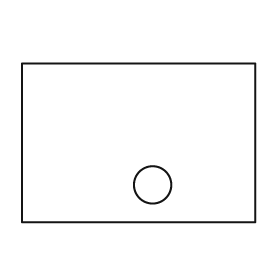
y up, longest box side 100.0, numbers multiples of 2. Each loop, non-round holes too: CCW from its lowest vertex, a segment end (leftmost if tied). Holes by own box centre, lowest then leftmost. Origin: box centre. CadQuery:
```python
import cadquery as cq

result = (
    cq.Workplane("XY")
    .moveTo(-50.0, -34.0)
    .lineTo(50.0, -34.0)
    .lineTo(50.0, 34.0)
    .lineTo(-50.0, 34.0)
    .close()
    .moveTo(6.0, -18.0)
    .circle(8.0)
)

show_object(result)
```